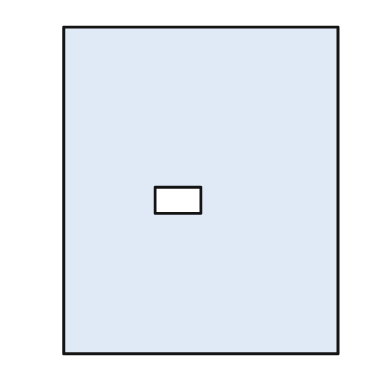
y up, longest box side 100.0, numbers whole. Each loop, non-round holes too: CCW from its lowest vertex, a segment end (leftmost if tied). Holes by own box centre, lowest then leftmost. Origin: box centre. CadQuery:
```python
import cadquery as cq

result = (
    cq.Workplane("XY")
    .moveTo(-42.0, -50.0)
    .lineTo(42.0, -50.0)
    .lineTo(42.0, 50.0)
    .lineTo(-42.0, 50.0)
    .close()
    .moveTo(-14.0, -7.0)
    .lineTo(0.0, -7.0)
    .lineTo(0.0, 1.0)
    .lineTo(-14.0, 1.0)
    .close()
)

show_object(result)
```